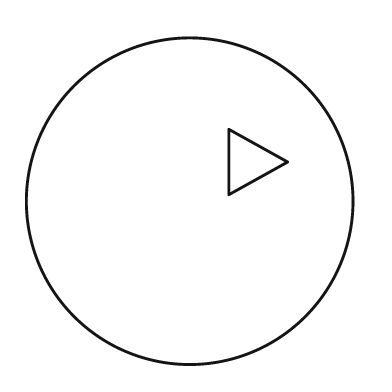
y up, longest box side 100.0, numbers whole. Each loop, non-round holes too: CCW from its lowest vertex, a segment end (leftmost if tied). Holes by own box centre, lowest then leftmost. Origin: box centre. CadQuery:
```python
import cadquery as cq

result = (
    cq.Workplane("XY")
    .moveTo(0.0, 0.0)
    .circle(50.0)
    .moveTo(12.0, 2.0)
    .lineTo(30.0, 12.0)
    .lineTo(12.0, 22.0)
    .close()
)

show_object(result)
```